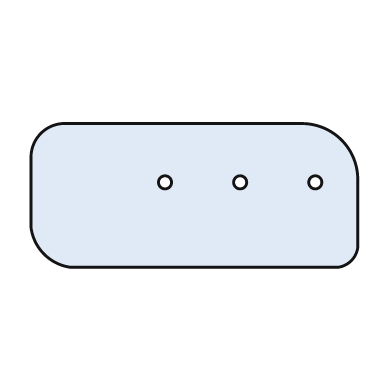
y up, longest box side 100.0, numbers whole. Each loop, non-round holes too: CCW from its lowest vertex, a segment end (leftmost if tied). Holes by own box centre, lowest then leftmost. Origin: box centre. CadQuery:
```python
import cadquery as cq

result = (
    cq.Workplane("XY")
    .moveTo(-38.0, -22.0)
    .lineTo(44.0, -22.0)
    .threePointArc((48.0, -20.0), (50.0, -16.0))
    .lineTo(50.0, 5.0)
    .threePointArc((45.0, 17.0), (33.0, 22.0))
    .lineTo(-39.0, 22.0)
    .threePointArc((-47.0, 19.0), (-50.0, 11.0))
    .lineTo(-50.0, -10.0)
    .threePointArc((-46.0, -18.0), (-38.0, -22.0))
    .close()
    .moveTo(-9.0, 4.0)
    .circle(2.0)
    .moveTo(14.0, 4.0)
    .circle(2.0)
    .moveTo(37.0, 4.0)
    .circle(2.0)
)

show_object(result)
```